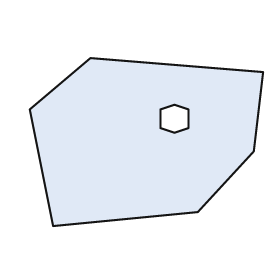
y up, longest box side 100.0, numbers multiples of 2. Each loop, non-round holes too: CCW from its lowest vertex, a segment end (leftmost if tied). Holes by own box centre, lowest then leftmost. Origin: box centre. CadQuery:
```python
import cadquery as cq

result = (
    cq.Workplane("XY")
    .moveTo(-40.0, -36.0)
    .lineTo(22.0, -30.0)
    .lineTo(46.0, -4.0)
    .lineTo(50.0, 30.0)
    .lineTo(-24.0, 36.0)
    .lineTo(-50.0, 14.0)
    .close()
    .moveTo(12.0, 4.0)
    .lineTo(18.0, 6.0)
    .lineTo(18.0, 14.0)
    .lineTo(12.0, 16.0)
    .lineTo(6.0, 14.0)
    .lineTo(6.0, 6.0)
    .close()
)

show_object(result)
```